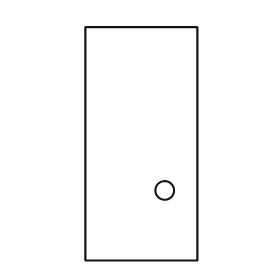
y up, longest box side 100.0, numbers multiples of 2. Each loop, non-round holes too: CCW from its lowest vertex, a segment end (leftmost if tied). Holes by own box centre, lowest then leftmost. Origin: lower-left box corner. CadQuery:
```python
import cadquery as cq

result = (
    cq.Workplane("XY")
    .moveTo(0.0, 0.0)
    .lineTo(48.0, 0.0)
    .lineTo(48.0, 100.0)
    .lineTo(0.0, 100.0)
    .close()
    .moveTo(34.0, 30.0)
    .circle(4.0)
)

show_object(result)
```